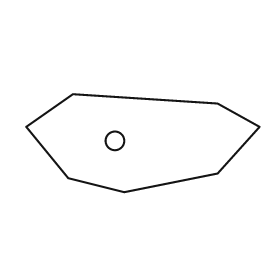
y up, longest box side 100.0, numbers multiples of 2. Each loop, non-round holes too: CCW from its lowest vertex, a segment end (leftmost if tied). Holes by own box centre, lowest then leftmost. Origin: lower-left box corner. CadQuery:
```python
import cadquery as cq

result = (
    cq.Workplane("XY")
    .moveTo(42.0, 0.0)
    .lineTo(82.0, 8.0)
    .lineTo(100.0, 28.0)
    .lineTo(82.0, 38.0)
    .lineTo(20.0, 42.0)
    .lineTo(0.0, 28.0)
    .lineTo(18.0, 6.0)
    .close()
    .moveTo(38.0, 22.0)
    .circle(4.0)
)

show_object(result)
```